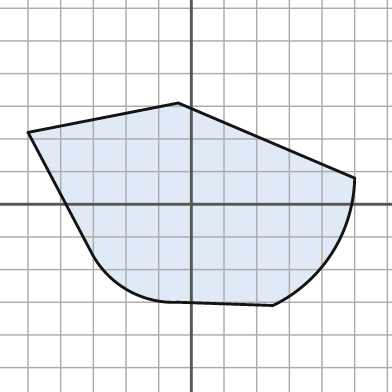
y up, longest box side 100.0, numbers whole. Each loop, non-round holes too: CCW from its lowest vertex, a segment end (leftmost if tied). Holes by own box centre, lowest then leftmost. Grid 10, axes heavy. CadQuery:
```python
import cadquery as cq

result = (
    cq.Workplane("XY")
    .moveTo(25.0, -31.0)
    .threePointArc((43.0, -15.0), (50.0, 8.0))
    .lineTo(-4.0, 31.0)
    .lineTo(-50.0, 22.0)
    .lineTo(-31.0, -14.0)
    .threePointArc((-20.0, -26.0), (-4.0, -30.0))
    .close()
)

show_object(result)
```